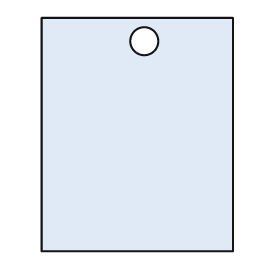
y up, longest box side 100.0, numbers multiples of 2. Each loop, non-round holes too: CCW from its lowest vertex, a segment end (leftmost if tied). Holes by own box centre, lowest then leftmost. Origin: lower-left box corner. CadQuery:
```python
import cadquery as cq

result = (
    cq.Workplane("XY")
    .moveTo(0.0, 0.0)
    .lineTo(82.0, 0.0)
    .lineTo(82.0, 100.0)
    .lineTo(0.0, 100.0)
    .close()
    .moveTo(44.0, 90.0)
    .circle(6.0)
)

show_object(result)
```